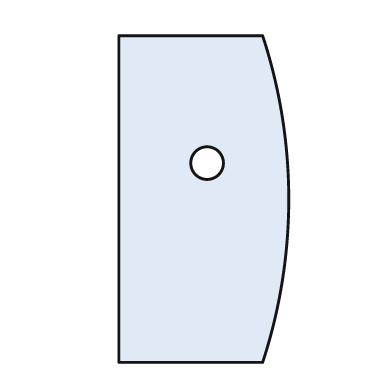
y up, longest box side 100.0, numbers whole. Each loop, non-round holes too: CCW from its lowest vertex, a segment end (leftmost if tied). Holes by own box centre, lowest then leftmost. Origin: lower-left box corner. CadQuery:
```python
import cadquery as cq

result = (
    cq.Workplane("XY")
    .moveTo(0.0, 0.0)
    .lineTo(44.0, 0.0)
    .threePointArc((52.0, 50.0), (44.0, 100.0))
    .lineTo(0.0, 100.0)
    .close()
    .moveTo(27.0, 61.0)
    .circle(5.0)
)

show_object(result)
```